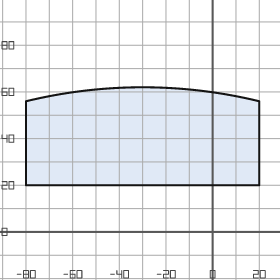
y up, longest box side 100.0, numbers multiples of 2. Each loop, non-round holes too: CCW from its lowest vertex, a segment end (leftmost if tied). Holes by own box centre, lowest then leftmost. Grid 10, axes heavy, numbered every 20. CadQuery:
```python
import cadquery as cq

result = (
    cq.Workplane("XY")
    .moveTo(-80.0, 20.0)
    .lineTo(20.0, 20.0)
    .lineTo(20.0, 56.0)
    .threePointArc((-30.0, 62.0), (-80.0, 56.0))
    .close()
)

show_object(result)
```